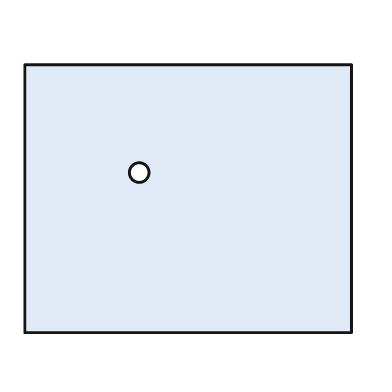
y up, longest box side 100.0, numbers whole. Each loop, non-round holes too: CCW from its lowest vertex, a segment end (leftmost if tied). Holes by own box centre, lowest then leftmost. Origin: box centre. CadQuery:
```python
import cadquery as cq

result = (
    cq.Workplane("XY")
    .moveTo(-50.0, -41.0)
    .lineTo(50.0, -41.0)
    .lineTo(50.0, 41.0)
    .lineTo(-50.0, 41.0)
    .close()
    .moveTo(-15.0, 8.0)
    .circle(3.0)
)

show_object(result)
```